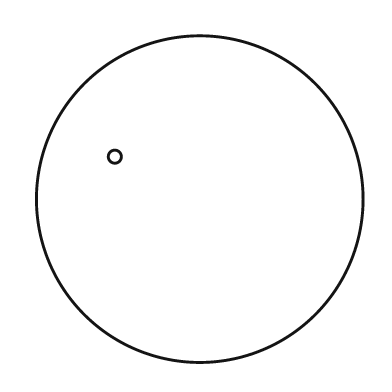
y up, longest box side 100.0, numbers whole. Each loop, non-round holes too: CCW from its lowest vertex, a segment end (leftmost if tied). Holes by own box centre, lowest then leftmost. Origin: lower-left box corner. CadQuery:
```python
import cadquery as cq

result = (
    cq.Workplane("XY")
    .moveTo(50.0, 50.0)
    .circle(50.0)
    .moveTo(24.0, 63.0)
    .circle(2.0)
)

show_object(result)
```